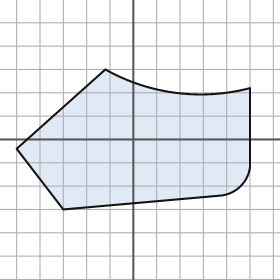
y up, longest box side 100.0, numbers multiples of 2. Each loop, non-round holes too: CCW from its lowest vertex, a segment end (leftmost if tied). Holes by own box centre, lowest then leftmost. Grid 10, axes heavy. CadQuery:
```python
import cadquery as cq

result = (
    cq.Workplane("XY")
    .moveTo(-30.0, -30.0)
    .lineTo(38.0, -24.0)
    .threePointArc((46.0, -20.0), (50.0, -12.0))
    .lineTo(50.0, 22.0)
    .threePointArc((18.0, 20.0), (-12.0, 30.0))
    .lineTo(-50.0, -4.0)
    .close()
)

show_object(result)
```